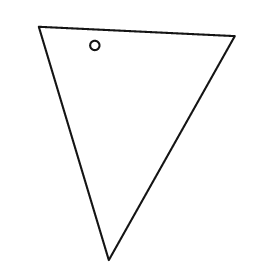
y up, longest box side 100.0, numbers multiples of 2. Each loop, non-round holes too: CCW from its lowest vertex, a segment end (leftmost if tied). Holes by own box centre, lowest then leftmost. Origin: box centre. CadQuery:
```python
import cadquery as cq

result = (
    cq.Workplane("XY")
    .moveTo(-12.0, -50.0)
    .lineTo(42.0, 46.0)
    .lineTo(-42.0, 50.0)
    .close()
    .moveTo(-18.0, 42.0)
    .circle(2.0)
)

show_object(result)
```